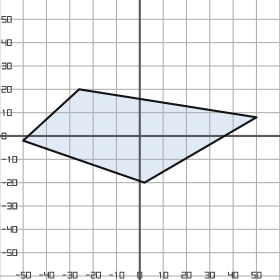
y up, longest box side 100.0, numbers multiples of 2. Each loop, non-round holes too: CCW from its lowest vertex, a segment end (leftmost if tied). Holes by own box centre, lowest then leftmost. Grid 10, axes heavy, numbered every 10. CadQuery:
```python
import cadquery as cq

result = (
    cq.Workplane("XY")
    .moveTo(2.0, -20.0)
    .lineTo(50.0, 8.0)
    .lineTo(-26.0, 20.0)
    .lineTo(-50.0, -2.0)
    .close()
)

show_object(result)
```